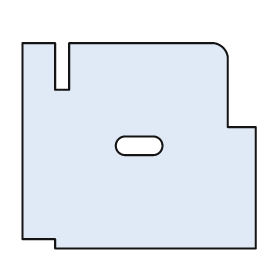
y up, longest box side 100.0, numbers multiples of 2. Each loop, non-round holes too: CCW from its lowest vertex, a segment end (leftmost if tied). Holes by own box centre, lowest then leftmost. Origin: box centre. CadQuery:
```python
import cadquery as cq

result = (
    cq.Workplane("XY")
    .moveTo(-36.0, -44.0)
    .lineTo(50.0, -44.0)
    .lineTo(50.0, 8.0)
    .lineTo(38.0, 8.0)
    .lineTo(38.0, 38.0)
    .threePointArc((36.0, 42.0), (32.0, 44.0))
    .lineTo(-30.0, 44.0)
    .lineTo(-30.0, 24.0)
    .lineTo(-36.0, 24.0)
    .lineTo(-36.0, 44.0)
    .lineTo(-50.0, 44.0)
    .lineTo(-50.0, -40.0)
    .lineTo(-36.0, -40.0)
    .close()
    .moveTo(-6.0, -4.0)
    .lineTo(6.0, -4.0)
    .threePointArc((10.0, 0.0), (6.0, 4.0))
    .lineTo(-6.0, 4.0)
    .threePointArc((-10.0, 0.0), (-6.0, -4.0))
    .close()
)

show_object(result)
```